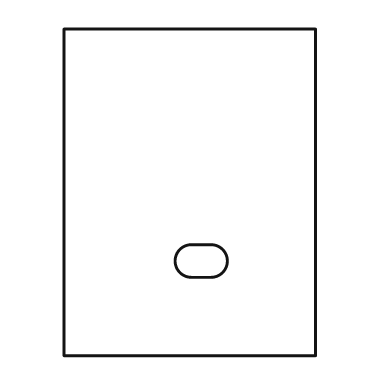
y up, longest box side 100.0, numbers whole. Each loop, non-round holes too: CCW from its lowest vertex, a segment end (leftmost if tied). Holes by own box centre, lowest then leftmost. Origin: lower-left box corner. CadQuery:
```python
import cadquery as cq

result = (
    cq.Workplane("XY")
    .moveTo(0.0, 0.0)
    .lineTo(77.0, 0.0)
    .lineTo(77.0, 100.0)
    .lineTo(0.0, 100.0)
    .close()
    .moveTo(39.0, 24.0)
    .lineTo(45.0, 24.0)
    .threePointArc((50.0, 29.0), (45.0, 34.0))
    .lineTo(39.0, 34.0)
    .threePointArc((34.0, 29.0), (39.0, 24.0))
    .close()
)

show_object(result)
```